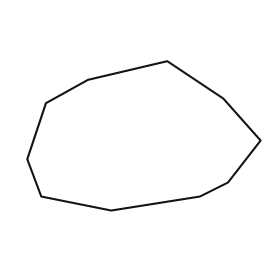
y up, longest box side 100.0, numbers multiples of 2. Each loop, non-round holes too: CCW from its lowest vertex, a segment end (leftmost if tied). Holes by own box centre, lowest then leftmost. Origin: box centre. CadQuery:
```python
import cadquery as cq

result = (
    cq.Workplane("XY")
    .moveTo(-14.0, -32.0)
    .lineTo(24.0, -26.0)
    .lineTo(36.0, -20.0)
    .lineTo(50.0, -2.0)
    .lineTo(34.0, 16.0)
    .lineTo(10.0, 32.0)
    .lineTo(-24.0, 24.0)
    .lineTo(-42.0, 14.0)
    .lineTo(-50.0, -10.0)
    .lineTo(-44.0, -26.0)
    .close()
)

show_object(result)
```